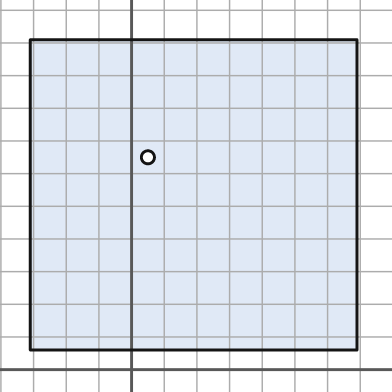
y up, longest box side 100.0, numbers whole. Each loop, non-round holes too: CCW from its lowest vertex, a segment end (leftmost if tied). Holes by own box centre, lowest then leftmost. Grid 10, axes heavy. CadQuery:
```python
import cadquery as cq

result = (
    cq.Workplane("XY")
    .moveTo(-31.0, 6.0)
    .lineTo(69.0, 6.0)
    .lineTo(69.0, 101.0)
    .lineTo(-31.0, 101.0)
    .close()
    .moveTo(5.0, 65.0)
    .circle(2.0)
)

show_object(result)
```